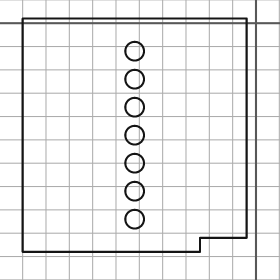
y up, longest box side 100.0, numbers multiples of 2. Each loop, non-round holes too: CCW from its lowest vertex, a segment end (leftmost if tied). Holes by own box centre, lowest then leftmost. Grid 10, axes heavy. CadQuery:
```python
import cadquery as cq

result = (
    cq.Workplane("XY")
    .moveTo(-100.0, -98.0)
    .lineTo(-24.0, -98.0)
    .lineTo(-24.0, -92.0)
    .lineTo(-4.0, -92.0)
    .lineTo(-4.0, 2.0)
    .lineTo(-100.0, 2.0)
    .close()
    .moveTo(-52.0, -84.0)
    .circle(4.0)
    .moveTo(-52.0, -72.0)
    .circle(4.0)
    .moveTo(-52.0, -60.0)
    .circle(4.0)
    .moveTo(-52.0, -48.0)
    .circle(4.0)
    .moveTo(-52.0, -36.0)
    .circle(4.0)
    .moveTo(-52.0, -24.0)
    .circle(4.0)
    .moveTo(-52.0, -12.0)
    .circle(4.0)
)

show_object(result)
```